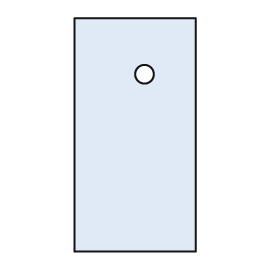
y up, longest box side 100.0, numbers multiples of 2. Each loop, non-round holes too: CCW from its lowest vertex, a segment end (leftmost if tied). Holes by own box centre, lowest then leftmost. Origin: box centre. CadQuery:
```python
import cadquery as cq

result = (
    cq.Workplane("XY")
    .moveTo(-26.0, -50.0)
    .lineTo(26.0, -50.0)
    .lineTo(26.0, 50.0)
    .lineTo(-26.0, 50.0)
    .close()
    .moveTo(4.0, 26.0)
    .circle(4.0)
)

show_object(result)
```